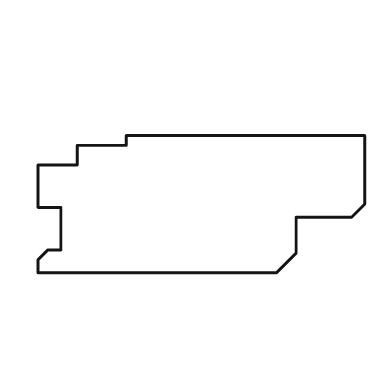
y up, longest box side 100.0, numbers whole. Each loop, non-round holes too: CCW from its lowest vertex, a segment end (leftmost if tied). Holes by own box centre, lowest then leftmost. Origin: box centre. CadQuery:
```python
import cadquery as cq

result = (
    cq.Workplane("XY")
    .moveTo(-50.0, -21.0)
    .lineTo(23.0, -21.0)
    .lineTo(29.0, -15.0)
    .lineTo(29.0, -4.0)
    .lineTo(46.0, -4.0)
    .lineTo(50.0, 0.0)
    .lineTo(50.0, 21.0)
    .lineTo(-23.0, 21.0)
    .lineTo(-23.0, 18.0)
    .lineTo(-38.0, 18.0)
    .lineTo(-38.0, 12.0)
    .lineTo(-50.0, 12.0)
    .lineTo(-50.0, -1.0)
    .lineTo(-43.0, -1.0)
    .lineTo(-43.0, -14.0)
    .lineTo(-47.0, -14.0)
    .lineTo(-50.0, -17.0)
    .close()
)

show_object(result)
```